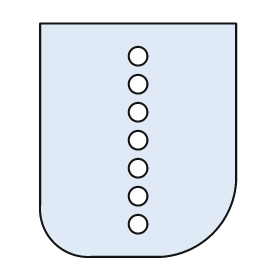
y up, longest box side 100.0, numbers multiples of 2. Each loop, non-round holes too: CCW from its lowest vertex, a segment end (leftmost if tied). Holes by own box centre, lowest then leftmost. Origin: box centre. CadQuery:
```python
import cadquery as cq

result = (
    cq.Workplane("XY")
    .moveTo(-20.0, -50.0)
    .lineTo(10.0, -50.0)
    .threePointArc((32.0, -40.0), (42.0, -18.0))
    .lineTo(42.0, 50.0)
    .lineTo(-42.0, 50.0)
    .lineTo(-42.0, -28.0)
    .threePointArc((-36.0, -44.0), (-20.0, -50.0))
    .close()
    .moveTo(0.0, -36.0)
    .circle(4.0)
    .moveTo(0.0, -24.0)
    .circle(4.0)
    .moveTo(0.0, -12.0)
    .circle(4.0)
    .moveTo(0.0, 0.0)
    .circle(4.0)
    .moveTo(0.0, 12.0)
    .circle(4.0)
    .moveTo(0.0, 24.0)
    .circle(4.0)
    .moveTo(0.0, 36.0)
    .circle(4.0)
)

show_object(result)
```